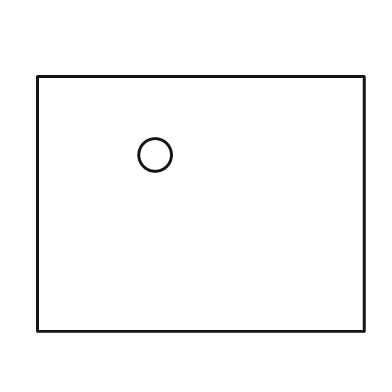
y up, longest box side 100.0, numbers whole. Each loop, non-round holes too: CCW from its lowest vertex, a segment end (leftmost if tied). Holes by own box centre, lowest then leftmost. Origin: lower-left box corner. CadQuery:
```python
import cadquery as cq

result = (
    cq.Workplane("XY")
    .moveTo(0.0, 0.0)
    .lineTo(100.0, 0.0)
    .lineTo(100.0, 78.0)
    .lineTo(0.0, 78.0)
    .close()
    .moveTo(36.0, 54.0)
    .circle(5.0)
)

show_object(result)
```